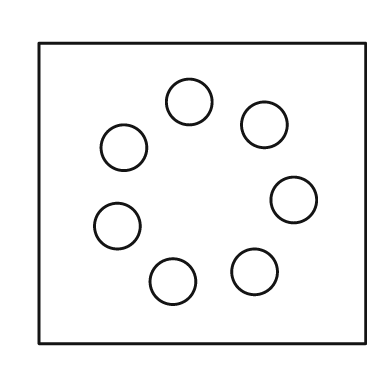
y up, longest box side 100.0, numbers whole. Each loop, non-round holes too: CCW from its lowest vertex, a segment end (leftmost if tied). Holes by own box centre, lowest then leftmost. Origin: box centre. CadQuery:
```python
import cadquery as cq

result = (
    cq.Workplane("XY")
    .moveTo(-50.0, -46.0)
    .lineTo(50.0, -46.0)
    .lineTo(50.0, 46.0)
    .lineTo(-50.0, 46.0)
    .close()
    .moveTo(-9.0, -27.0)
    .circle(7.0)
    .moveTo(16.0, -24.0)
    .circle(7.0)
    .moveTo(-26.0, -10.0)
    .circle(7.0)
    .moveTo(28.0, -2.0)
    .circle(7.0)
    .moveTo(-24.0, 14.0)
    .circle(7.0)
    .moveTo(19.0, 21.0)
    .circle(7.0)
    .moveTo(-4.0, 28.0)
    .circle(7.0)
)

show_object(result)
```